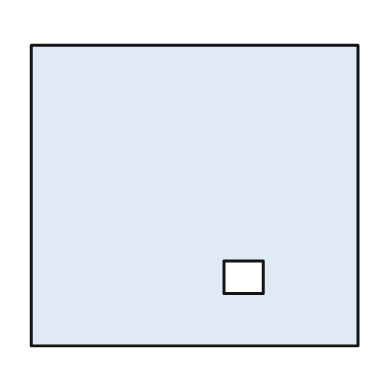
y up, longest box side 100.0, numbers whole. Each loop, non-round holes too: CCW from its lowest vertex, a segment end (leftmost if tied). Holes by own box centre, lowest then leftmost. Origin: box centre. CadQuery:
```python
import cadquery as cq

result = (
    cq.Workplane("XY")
    .moveTo(-50.0, -46.0)
    .lineTo(50.0, -46.0)
    .lineTo(50.0, 46.0)
    .lineTo(-50.0, 46.0)
    .close()
    .moveTo(9.0, -30.0)
    .lineTo(21.0, -30.0)
    .lineTo(21.0, -20.0)
    .lineTo(9.0, -20.0)
    .close()
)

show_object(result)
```